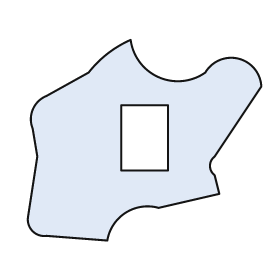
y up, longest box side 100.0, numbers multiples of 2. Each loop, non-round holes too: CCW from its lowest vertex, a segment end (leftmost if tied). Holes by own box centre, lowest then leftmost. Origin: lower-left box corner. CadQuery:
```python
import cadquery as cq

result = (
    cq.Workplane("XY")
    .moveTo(34.0, 0.0)
    .threePointArc((42.0, 12.0), (56.0, 14.0))
    .lineTo(82.0, 20.0)
    .lineTo(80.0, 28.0)
    .threePointArc((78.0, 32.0), (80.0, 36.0))
    .lineTo(100.0, 66.0)
    .threePointArc((90.0, 78.0), (76.0, 72.0))
    .threePointArc((56.0, 70.0), (44.0, 86.0))
    .threePointArc((34.0, 80.0), (26.0, 72.0))
    .lineTo(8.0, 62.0)
    .threePointArc((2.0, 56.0), (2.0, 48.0))
    .lineTo(4.0, 36.0)
    .lineTo(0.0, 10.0)
    .threePointArc((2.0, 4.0), (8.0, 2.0))
    .close()
    .moveTo(40.0, 30.0)
    .lineTo(60.0, 30.0)
    .lineTo(60.0, 58.0)
    .lineTo(40.0, 58.0)
    .close()
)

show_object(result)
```